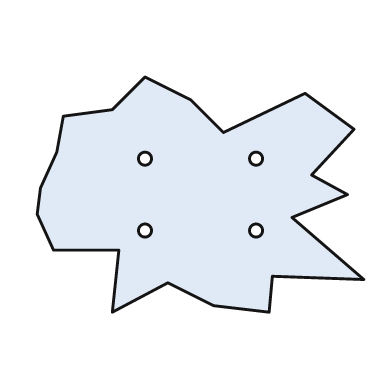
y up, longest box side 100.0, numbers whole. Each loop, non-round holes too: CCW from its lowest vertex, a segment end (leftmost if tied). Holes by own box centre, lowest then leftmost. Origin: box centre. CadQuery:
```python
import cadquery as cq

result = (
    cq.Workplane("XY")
    .moveTo(-27.0, -36.0)
    .lineTo(-10.0, -27.0)
    .lineTo(4.0, -34.0)
    .lineTo(21.0, -36.0)
    .lineTo(22.0, -25.0)
    .lineTo(50.0, -26.0)
    .lineTo(28.0, -7.0)
    .lineTo(45.0, 0.0)
    .lineTo(34.0, 6.0)
    .lineTo(47.0, 20.0)
    .lineTo(32.0, 31.0)
    .lineTo(7.0, 19.0)
    .lineTo(-3.0, 29.0)
    .lineTo(-17.0, 36.0)
    .lineTo(-27.0, 26.0)
    .lineTo(-42.0, 24.0)
    .lineTo(-44.0, 13.0)
    .lineTo(-49.0, 2.0)
    .lineTo(-50.0, -6.0)
    .lineTo(-45.0, -17.0)
    .lineTo(-25.0, -17.0)
    .close()
    .moveTo(-17.0, -11.0)
    .circle(2.0)
    .moveTo(17.0, -11.0)
    .circle(2.0)
    .moveTo(-17.0, 11.0)
    .circle(2.0)
    .moveTo(17.0, 11.0)
    .circle(2.0)
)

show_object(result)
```